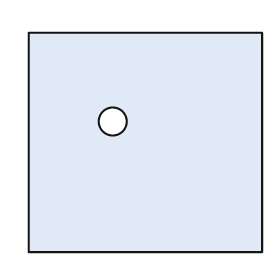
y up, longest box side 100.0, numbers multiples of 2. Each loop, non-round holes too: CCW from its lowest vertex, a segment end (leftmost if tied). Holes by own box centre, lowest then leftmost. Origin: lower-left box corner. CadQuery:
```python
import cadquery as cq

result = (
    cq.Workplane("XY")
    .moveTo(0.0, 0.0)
    .lineTo(100.0, 0.0)
    .lineTo(100.0, 94.0)
    .lineTo(0.0, 94.0)
    .close()
    .moveTo(36.0, 56.0)
    .circle(6.0)
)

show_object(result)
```